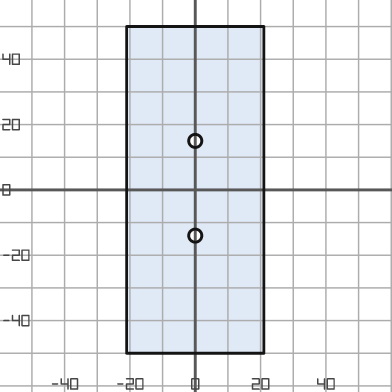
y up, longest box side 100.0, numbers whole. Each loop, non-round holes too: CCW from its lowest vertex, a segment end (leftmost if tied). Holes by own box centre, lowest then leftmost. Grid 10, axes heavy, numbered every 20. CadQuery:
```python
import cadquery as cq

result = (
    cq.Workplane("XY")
    .moveTo(-21.0, -50.0)
    .lineTo(21.0, -50.0)
    .lineTo(21.0, 50.0)
    .lineTo(-21.0, 50.0)
    .close()
    .moveTo(0.0, -14.0)
    .circle(2.0)
    .moveTo(0.0, 15.0)
    .circle(2.0)
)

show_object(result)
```